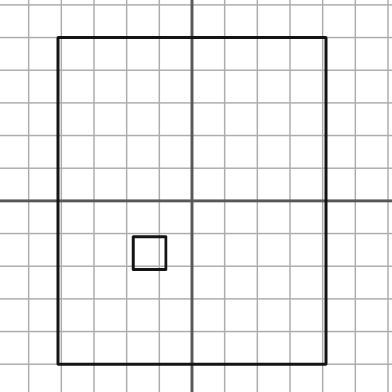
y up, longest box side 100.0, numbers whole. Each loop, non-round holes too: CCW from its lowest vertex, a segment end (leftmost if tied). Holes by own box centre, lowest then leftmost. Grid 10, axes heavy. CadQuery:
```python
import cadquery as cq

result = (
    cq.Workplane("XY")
    .moveTo(-41.0, -50.0)
    .lineTo(41.0, -50.0)
    .lineTo(41.0, 50.0)
    .lineTo(-41.0, 50.0)
    .close()
    .moveTo(-18.0, -21.0)
    .lineTo(-8.0, -21.0)
    .lineTo(-8.0, -11.0)
    .lineTo(-18.0, -11.0)
    .close()
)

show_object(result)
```